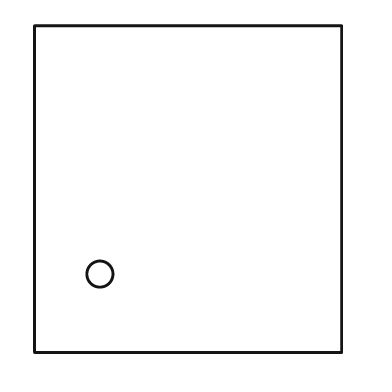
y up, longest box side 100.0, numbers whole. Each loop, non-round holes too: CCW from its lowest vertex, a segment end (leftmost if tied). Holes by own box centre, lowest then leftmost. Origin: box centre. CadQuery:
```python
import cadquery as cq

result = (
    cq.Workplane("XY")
    .moveTo(-47.0, -50.0)
    .lineTo(47.0, -50.0)
    .lineTo(47.0, 50.0)
    .lineTo(-47.0, 50.0)
    .close()
    .moveTo(-27.0, -26.0)
    .circle(4.0)
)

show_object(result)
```